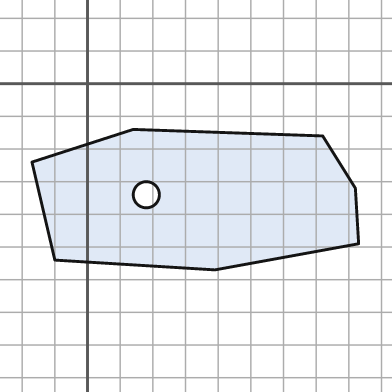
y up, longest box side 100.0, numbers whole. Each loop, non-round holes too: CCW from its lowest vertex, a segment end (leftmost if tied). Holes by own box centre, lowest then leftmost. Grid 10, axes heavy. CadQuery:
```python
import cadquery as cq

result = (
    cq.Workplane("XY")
    .moveTo(39.0, -57.0)
    .lineTo(83.0, -49.0)
    .lineTo(82.0, -32.0)
    .lineTo(72.0, -16.0)
    .lineTo(14.0, -14.0)
    .lineTo(-17.0, -24.0)
    .lineTo(-10.0, -54.0)
    .close()
    .moveTo(18.0, -34.0)
    .circle(4.0)
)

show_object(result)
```